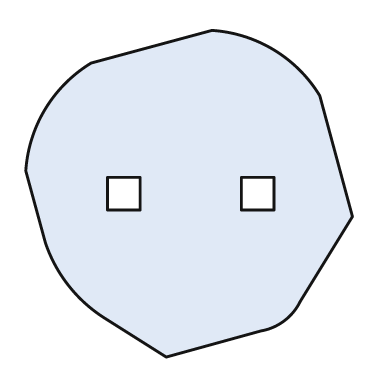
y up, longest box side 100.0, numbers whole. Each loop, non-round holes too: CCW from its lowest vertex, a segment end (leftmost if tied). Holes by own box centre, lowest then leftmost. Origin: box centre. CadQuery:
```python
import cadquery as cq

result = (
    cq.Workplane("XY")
    .moveTo(-7.0, -50.0)
    .lineTo(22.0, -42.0)
    .threePointArc((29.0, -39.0), (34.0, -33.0))
    .lineTo(50.0, -7.0)
    .lineTo(40.0, 30.0)
    .threePointArc((26.0, 44.0), (7.0, 50.0))
    .lineTo(-30.0, 40.0)
    .threePointArc((-44.0, 26.0), (-50.0, 7.0))
    .lineTo(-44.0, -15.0)
    .threePointArc((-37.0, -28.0), (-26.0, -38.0))
    .close()
    .moveTo(-25.0, -5.0)
    .lineTo(-15.0, -5.0)
    .lineTo(-15.0, 5.0)
    .lineTo(-25.0, 5.0)
    .close()
    .moveTo(16.0, -5.0)
    .lineTo(26.0, -5.0)
    .lineTo(26.0, 5.0)
    .lineTo(16.0, 5.0)
    .close()
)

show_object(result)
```